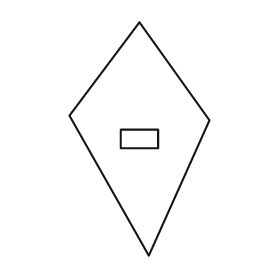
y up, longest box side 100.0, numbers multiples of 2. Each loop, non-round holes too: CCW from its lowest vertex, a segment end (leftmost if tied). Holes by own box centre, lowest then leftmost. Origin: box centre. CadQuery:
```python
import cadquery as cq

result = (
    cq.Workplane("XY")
    .moveTo(4.0, -50.0)
    .lineTo(30.0, 8.0)
    .lineTo(0.0, 50.0)
    .lineTo(-30.0, 10.0)
    .close()
    .moveTo(-8.0, -4.0)
    .lineTo(8.0, -4.0)
    .lineTo(8.0, 4.0)
    .lineTo(-8.0, 4.0)
    .close()
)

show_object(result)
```